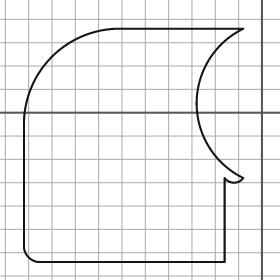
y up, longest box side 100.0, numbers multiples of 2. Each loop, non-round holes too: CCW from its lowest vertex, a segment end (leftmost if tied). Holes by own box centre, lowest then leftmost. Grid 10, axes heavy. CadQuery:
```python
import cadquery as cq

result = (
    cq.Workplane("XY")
    .moveTo(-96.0, -64.0)
    .lineTo(-16.0, -64.0)
    .lineTo(-16.0, -28.0)
    .threePointArc((-12.0, -30.0), (-8.0, -28.0))
    .threePointArc((-28.0, 4.0), (-8.0, 36.0))
    .lineTo(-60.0, 36.0)
    .threePointArc((-90.0, 24.0), (-102.0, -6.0))
    .lineTo(-102.0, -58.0)
    .threePointArc((-100.0, -62.0), (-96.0, -64.0))
    .close()
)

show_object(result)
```